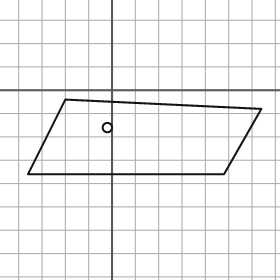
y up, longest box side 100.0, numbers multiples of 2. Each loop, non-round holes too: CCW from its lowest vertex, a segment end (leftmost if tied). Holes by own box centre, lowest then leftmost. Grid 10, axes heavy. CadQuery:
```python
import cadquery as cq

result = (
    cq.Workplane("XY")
    .moveTo(-36.0, -36.0)
    .lineTo(48.0, -36.0)
    .lineTo(64.0, -8.0)
    .lineTo(-20.0, -4.0)
    .close()
    .moveTo(-2.0, -16.0)
    .circle(2.0)
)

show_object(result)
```